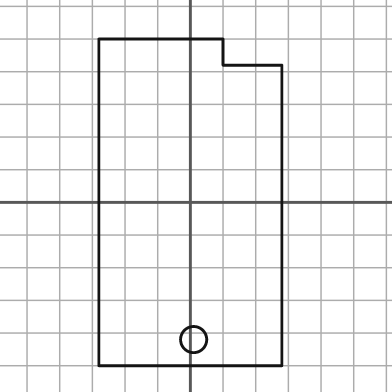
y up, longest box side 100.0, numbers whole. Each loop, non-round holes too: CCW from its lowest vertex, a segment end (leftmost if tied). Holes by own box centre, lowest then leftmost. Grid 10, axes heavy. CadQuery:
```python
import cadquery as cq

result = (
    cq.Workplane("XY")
    .moveTo(-28.0, -50.0)
    .lineTo(28.0, -50.0)
    .lineTo(28.0, 42.0)
    .lineTo(10.0, 42.0)
    .lineTo(10.0, 50.0)
    .lineTo(-28.0, 50.0)
    .close()
    .moveTo(1.0, -42.0)
    .circle(4.0)
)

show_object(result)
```